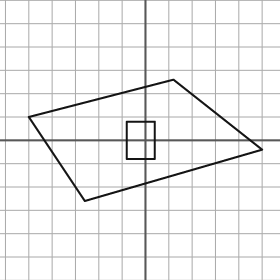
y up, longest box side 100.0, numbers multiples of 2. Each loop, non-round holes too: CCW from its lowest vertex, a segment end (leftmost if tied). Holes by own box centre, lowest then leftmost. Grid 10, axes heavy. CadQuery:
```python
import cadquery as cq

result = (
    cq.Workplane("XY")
    .moveTo(-26.0, -26.0)
    .lineTo(50.0, -4.0)
    .lineTo(12.0, 26.0)
    .lineTo(-50.0, 10.0)
    .close()
    .moveTo(-8.0, -8.0)
    .lineTo(4.0, -8.0)
    .lineTo(4.0, 8.0)
    .lineTo(-8.0, 8.0)
    .close()
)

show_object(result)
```